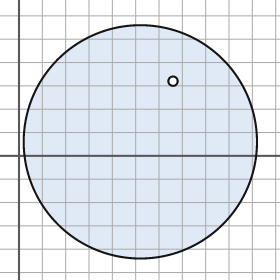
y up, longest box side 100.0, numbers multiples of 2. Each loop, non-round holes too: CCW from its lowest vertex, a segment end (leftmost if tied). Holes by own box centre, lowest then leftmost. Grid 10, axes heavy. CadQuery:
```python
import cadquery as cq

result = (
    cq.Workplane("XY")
    .moveTo(52.0, 6.0)
    .circle(50.0)
    .moveTo(66.0, 32.0)
    .circle(2.0)
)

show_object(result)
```